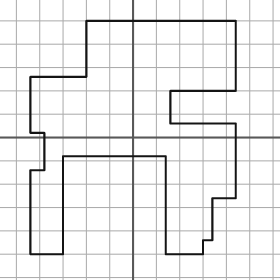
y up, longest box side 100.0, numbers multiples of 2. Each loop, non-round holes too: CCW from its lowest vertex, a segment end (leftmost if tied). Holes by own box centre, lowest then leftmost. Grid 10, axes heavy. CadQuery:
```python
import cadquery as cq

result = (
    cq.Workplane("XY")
    .moveTo(-44.0, -50.0)
    .lineTo(-30.0, -50.0)
    .lineTo(-30.0, -8.0)
    .lineTo(14.0, -8.0)
    .lineTo(14.0, -50.0)
    .lineTo(30.0, -50.0)
    .lineTo(30.0, -44.0)
    .lineTo(34.0, -44.0)
    .lineTo(34.0, -26.0)
    .lineTo(44.0, -26.0)
    .lineTo(44.0, 6.0)
    .lineTo(16.0, 6.0)
    .lineTo(16.0, 20.0)
    .lineTo(44.0, 20.0)
    .lineTo(44.0, 50.0)
    .lineTo(-20.0, 50.0)
    .lineTo(-20.0, 26.0)
    .lineTo(-44.0, 26.0)
    .lineTo(-44.0, 2.0)
    .lineTo(-38.0, 2.0)
    .lineTo(-38.0, -14.0)
    .lineTo(-44.0, -14.0)
    .close()
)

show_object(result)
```